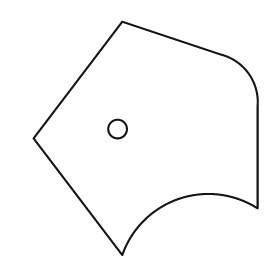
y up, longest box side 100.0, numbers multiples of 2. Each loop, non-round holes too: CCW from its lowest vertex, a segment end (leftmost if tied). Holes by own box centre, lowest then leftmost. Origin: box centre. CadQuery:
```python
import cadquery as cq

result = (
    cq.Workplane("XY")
    .moveTo(-10.0, -50.0)
    .threePointArc((14.0, -26.0), (48.0, -30.0))
    .lineTo(48.0, 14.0)
    .threePointArc((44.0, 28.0), (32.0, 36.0))
    .lineTo(-10.0, 50.0)
    .lineTo(-48.0, 0.0)
    .close()
    .moveTo(-12.0, 4.0)
    .circle(4.0)
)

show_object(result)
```